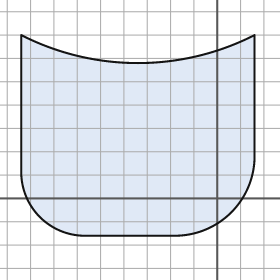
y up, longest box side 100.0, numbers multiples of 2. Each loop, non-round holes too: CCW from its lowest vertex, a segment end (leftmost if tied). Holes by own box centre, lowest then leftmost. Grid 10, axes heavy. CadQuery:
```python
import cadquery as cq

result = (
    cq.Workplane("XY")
    .moveTo(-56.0, -16.0)
    .lineTo(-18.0, -16.0)
    .threePointArc((6.0, -6.0), (16.0, 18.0))
    .lineTo(16.0, 70.0)
    .threePointArc((-34.0, 58.0), (-84.0, 70.0))
    .lineTo(-84.0, 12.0)
    .threePointArc((-76.0, -8.0), (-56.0, -16.0))
    .close()
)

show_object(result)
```